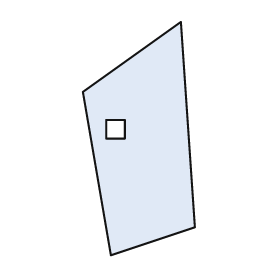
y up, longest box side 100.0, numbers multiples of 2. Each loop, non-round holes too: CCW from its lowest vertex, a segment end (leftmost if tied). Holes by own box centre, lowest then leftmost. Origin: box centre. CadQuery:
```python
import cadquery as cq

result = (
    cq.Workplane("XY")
    .moveTo(-12.0, -50.0)
    .lineTo(24.0, -38.0)
    .lineTo(18.0, 50.0)
    .lineTo(-24.0, 20.0)
    .close()
    .moveTo(-14.0, 0.0)
    .lineTo(-6.0, 0.0)
    .lineTo(-6.0, 8.0)
    .lineTo(-14.0, 8.0)
    .close()
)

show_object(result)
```